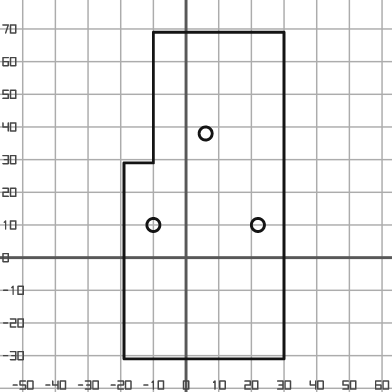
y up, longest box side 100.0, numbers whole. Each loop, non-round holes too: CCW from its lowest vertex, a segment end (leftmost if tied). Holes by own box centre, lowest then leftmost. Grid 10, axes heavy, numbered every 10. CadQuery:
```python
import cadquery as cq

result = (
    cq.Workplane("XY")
    .moveTo(-19.0, -31.0)
    .lineTo(30.0, -31.0)
    .lineTo(30.0, 69.0)
    .lineTo(-10.0, 69.0)
    .lineTo(-10.0, 29.0)
    .lineTo(-19.0, 29.0)
    .close()
    .moveTo(-10.0, 10.0)
    .circle(2.0)
    .moveTo(22.0, 10.0)
    .circle(2.0)
    .moveTo(6.0, 38.0)
    .circle(2.0)
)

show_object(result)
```